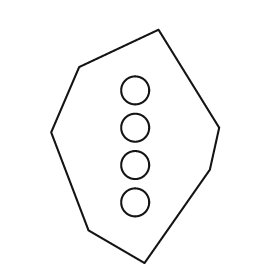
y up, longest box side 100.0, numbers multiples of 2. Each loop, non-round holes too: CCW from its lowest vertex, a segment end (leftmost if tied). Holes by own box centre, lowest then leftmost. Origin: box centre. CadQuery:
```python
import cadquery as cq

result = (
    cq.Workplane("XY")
    .moveTo(4.0, -50.0)
    .lineTo(32.0, -10.0)
    .lineTo(36.0, 8.0)
    .lineTo(10.0, 50.0)
    .lineTo(-24.0, 34.0)
    .lineTo(-36.0, 6.0)
    .lineTo(-20.0, -36.0)
    .close()
    .moveTo(0.0, -24.0)
    .circle(6.0)
    .moveTo(0.0, -8.0)
    .circle(6.0)
    .moveTo(0.0, 8.0)
    .circle(6.0)
    .moveTo(0.0, 24.0)
    .circle(6.0)
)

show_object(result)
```